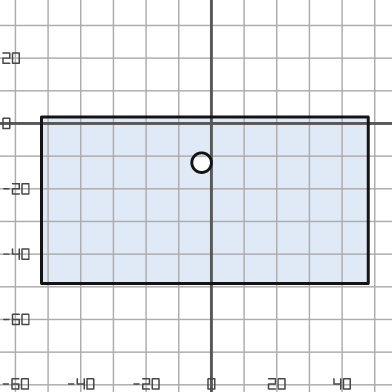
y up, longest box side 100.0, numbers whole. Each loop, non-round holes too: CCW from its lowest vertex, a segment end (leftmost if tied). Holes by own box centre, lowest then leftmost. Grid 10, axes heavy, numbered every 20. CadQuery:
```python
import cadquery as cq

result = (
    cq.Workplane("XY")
    .moveTo(-52.0, -49.0)
    .lineTo(48.0, -49.0)
    .lineTo(48.0, 2.0)
    .lineTo(-52.0, 2.0)
    .close()
    .moveTo(-3.0, -12.0)
    .circle(3.0)
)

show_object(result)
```